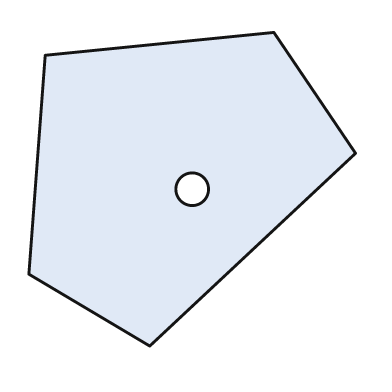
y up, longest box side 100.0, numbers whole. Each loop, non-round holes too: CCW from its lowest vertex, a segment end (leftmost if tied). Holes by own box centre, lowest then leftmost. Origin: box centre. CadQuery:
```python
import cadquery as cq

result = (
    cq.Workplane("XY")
    .moveTo(-13.0, -48.0)
    .lineTo(50.0, 11.0)
    .lineTo(25.0, 48.0)
    .lineTo(-45.0, 41.0)
    .lineTo(-50.0, -26.0)
    .close()
    .moveTo(0.0, 0.0)
    .circle(5.0)
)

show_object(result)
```